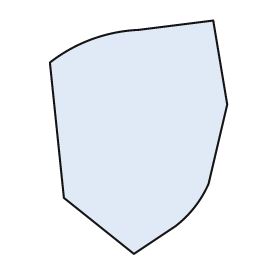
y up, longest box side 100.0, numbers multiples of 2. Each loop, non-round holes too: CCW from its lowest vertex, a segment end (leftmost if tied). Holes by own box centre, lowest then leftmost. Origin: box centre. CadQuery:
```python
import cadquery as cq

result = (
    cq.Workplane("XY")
    .moveTo(-2.0, -50.0)
    .lineTo(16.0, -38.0)
    .threePointArc((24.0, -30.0), (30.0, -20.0))
    .lineTo(38.0, 14.0)
    .lineTo(32.0, 50.0)
    .lineTo(0.0, 46.0)
    .threePointArc((-20.0, 42.0), (-38.0, 32.0))
    .lineTo(-32.0, -26.0)
    .close()
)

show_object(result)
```